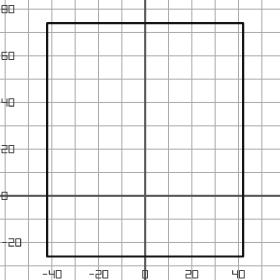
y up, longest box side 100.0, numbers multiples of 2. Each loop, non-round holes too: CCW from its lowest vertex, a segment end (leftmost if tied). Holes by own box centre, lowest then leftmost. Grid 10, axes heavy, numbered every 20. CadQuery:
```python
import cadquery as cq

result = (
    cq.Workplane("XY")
    .moveTo(-42.0, -26.0)
    .lineTo(42.0, -26.0)
    .lineTo(42.0, 74.0)
    .lineTo(-42.0, 74.0)
    .close()
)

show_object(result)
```